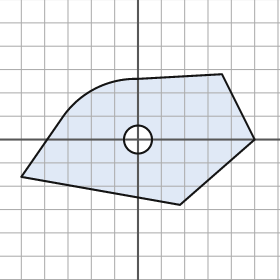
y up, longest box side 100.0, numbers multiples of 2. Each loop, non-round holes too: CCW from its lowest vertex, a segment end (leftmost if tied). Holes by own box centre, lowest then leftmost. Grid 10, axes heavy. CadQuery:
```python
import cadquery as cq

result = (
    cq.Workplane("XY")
    .moveTo(18.0, -28.0)
    .lineTo(50.0, 0.0)
    .lineTo(36.0, 28.0)
    .lineTo(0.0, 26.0)
    .threePointArc((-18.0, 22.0), (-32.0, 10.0))
    .lineTo(-50.0, -16.0)
    .close()
    .moveTo(0.0, 0.0)
    .circle(6.0)
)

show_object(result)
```